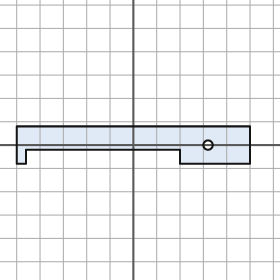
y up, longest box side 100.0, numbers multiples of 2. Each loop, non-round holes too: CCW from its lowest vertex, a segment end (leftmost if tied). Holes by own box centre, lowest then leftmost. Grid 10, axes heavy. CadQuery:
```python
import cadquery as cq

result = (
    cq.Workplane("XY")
    .moveTo(-50.0, -8.0)
    .lineTo(-46.0, -8.0)
    .lineTo(-46.0, -2.0)
    .lineTo(20.0, -2.0)
    .lineTo(20.0, -8.0)
    .lineTo(50.0, -8.0)
    .lineTo(50.0, 8.0)
    .lineTo(-50.0, 8.0)
    .close()
    .moveTo(32.0, 0.0)
    .circle(2.0)
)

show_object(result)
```